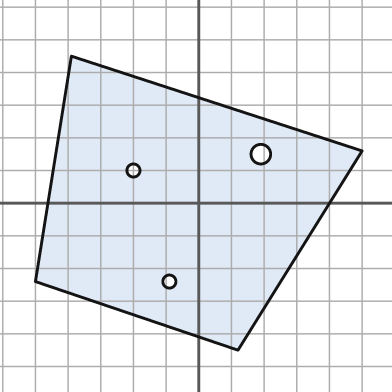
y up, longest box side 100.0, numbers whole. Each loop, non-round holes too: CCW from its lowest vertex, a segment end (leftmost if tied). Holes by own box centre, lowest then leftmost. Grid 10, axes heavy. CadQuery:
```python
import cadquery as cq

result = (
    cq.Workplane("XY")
    .moveTo(12.0, -45.0)
    .lineTo(50.0, 16.0)
    .lineTo(-39.0, 45.0)
    .lineTo(-50.0, -24.0)
    .close()
    .moveTo(-9.0, -24.0)
    .circle(2.0)
    .moveTo(-20.0, 10.0)
    .circle(2.0)
    .moveTo(19.0, 15.0)
    .circle(3.0)
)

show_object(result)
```